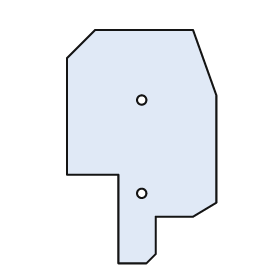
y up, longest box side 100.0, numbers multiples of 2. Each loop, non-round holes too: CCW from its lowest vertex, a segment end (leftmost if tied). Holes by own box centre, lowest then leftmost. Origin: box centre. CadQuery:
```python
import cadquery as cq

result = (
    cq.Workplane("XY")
    .moveTo(-10.0, -50.0)
    .lineTo(2.0, -50.0)
    .lineTo(6.0, -46.0)
    .lineTo(6.0, -30.0)
    .lineTo(22.0, -30.0)
    .lineTo(32.0, -24.0)
    .lineTo(32.0, 22.0)
    .lineTo(22.0, 50.0)
    .lineTo(-20.0, 50.0)
    .lineTo(-32.0, 38.0)
    .lineTo(-32.0, -12.0)
    .lineTo(-10.0, -12.0)
    .close()
    .moveTo(0.0, -20.0)
    .circle(2.0)
    .moveTo(0.0, 20.0)
    .circle(2.0)
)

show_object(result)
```